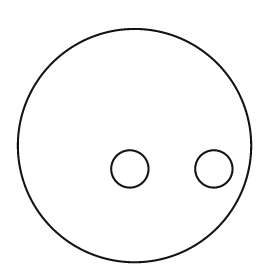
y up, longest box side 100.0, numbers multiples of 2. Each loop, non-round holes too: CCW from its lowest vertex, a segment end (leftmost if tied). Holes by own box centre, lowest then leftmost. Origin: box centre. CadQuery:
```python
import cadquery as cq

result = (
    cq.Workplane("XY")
    .moveTo(0.0, 0.0)
    .circle(50.0)
    .moveTo(-2.0, -10.0)
    .circle(8.0)
    .moveTo(34.0, -10.0)
    .circle(8.0)
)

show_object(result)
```